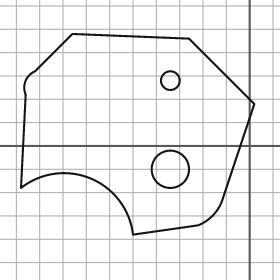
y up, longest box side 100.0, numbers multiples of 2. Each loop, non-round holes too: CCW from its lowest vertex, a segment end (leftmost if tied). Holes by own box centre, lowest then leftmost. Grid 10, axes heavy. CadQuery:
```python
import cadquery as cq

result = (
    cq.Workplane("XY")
    .moveTo(-50.0, -38.0)
    .lineTo(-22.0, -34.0)
    .threePointArc((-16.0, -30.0), (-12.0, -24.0))
    .lineTo(2.0, 18.0)
    .lineTo(-26.0, 46.0)
    .lineTo(-76.0, 48.0)
    .lineTo(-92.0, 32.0)
    .threePointArc((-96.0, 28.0), (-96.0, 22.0))
    .lineTo(-98.0, -18.0)
    .threePointArc((-68.0, -14.0), (-50.0, -38.0))
    .close()
    .moveTo(-34.0, -10.0)
    .circle(8.0)
    .moveTo(-34.0, 28.0)
    .circle(4.0)
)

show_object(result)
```